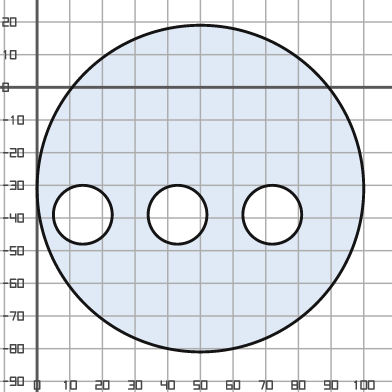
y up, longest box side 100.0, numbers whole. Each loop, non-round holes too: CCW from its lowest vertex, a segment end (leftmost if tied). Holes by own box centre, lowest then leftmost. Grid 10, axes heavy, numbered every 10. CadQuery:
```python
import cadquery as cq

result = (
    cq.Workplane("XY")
    .moveTo(50.0, -31.0)
    .circle(50.0)
    .moveTo(14.0, -39.0)
    .circle(9.0)
    .moveTo(43.0, -39.0)
    .circle(9.0)
    .moveTo(72.0, -39.0)
    .circle(9.0)
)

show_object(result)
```